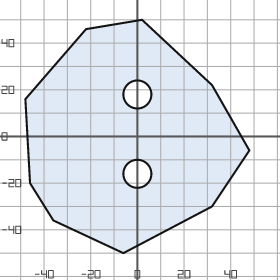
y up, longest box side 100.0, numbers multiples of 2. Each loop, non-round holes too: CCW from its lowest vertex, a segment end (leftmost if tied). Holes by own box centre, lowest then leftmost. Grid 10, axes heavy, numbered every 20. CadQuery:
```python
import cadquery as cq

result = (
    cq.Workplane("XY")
    .moveTo(-6.0, -50.0)
    .lineTo(32.0, -30.0)
    .lineTo(48.0, -6.0)
    .lineTo(32.0, 22.0)
    .lineTo(2.0, 50.0)
    .lineTo(-22.0, 46.0)
    .lineTo(-48.0, 16.0)
    .lineTo(-46.0, -20.0)
    .lineTo(-36.0, -36.0)
    .close()
    .moveTo(0.0, -16.0)
    .circle(6.0)
    .moveTo(0.0, 18.0)
    .circle(6.0)
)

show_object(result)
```